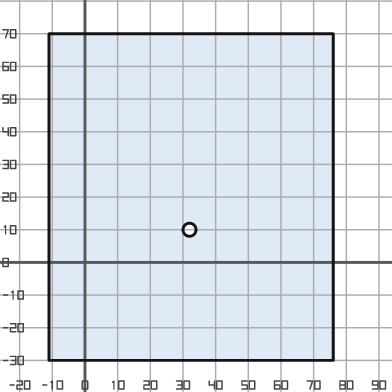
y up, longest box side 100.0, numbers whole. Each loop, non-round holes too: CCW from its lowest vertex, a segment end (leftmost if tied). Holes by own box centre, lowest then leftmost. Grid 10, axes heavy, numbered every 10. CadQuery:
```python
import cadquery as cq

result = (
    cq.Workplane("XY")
    .moveTo(-11.0, -30.0)
    .lineTo(76.0, -30.0)
    .lineTo(76.0, 70.0)
    .lineTo(-11.0, 70.0)
    .close()
    .moveTo(32.0, 10.0)
    .circle(2.0)
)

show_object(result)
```